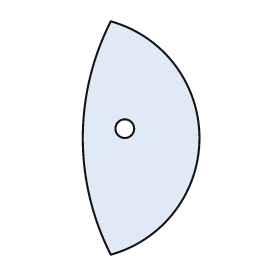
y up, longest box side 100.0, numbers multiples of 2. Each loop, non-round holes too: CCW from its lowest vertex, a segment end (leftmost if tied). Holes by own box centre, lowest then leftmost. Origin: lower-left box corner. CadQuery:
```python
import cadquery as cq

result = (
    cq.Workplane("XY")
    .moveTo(12.0, 0.0)
    .threePointArc((50.0, 50.0), (12.0, 100.0))
    .threePointArc((0.0, 50.0), (12.0, 0.0))
    .close()
    .moveTo(18.0, 54.0)
    .circle(4.0)
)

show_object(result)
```